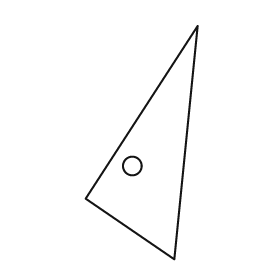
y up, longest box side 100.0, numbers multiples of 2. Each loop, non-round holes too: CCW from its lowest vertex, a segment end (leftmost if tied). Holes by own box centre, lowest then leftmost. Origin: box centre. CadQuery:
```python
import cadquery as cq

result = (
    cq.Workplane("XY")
    .moveTo(14.0, -50.0)
    .lineTo(24.0, 50.0)
    .lineTo(-24.0, -24.0)
    .close()
    .moveTo(-4.0, -10.0)
    .circle(4.0)
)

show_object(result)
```